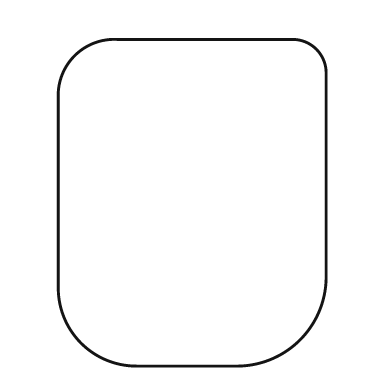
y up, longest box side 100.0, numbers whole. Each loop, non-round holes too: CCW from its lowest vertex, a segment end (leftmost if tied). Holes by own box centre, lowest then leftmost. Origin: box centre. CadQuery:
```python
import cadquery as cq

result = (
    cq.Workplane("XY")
    .moveTo(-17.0, -50.0)
    .lineTo(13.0, -50.0)
    .threePointArc((33.0, -42.0), (41.0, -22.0))
    .lineTo(41.0, 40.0)
    .threePointArc((38.0, 47.0), (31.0, 50.0))
    .lineTo(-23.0, 50.0)
    .threePointArc((-36.0, 45.0), (-41.0, 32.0))
    .lineTo(-41.0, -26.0)
    .threePointArc((-34.0, -43.0), (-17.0, -50.0))
    .close()
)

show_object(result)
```